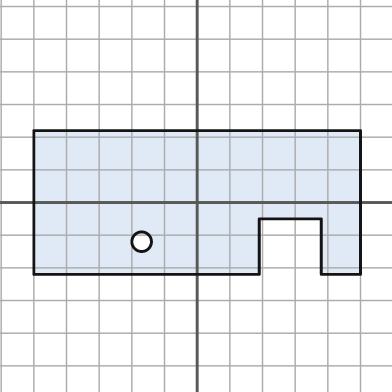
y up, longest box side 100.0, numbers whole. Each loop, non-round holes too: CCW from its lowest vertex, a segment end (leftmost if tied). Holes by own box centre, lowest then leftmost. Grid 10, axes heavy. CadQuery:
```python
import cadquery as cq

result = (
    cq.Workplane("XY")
    .moveTo(-50.0, -22.0)
    .lineTo(19.0, -22.0)
    .lineTo(19.0, -5.0)
    .lineTo(38.0, -5.0)
    .lineTo(38.0, -22.0)
    .lineTo(50.0, -22.0)
    .lineTo(50.0, 22.0)
    .lineTo(-50.0, 22.0)
    .close()
    .moveTo(-17.0, -12.0)
    .circle(3.0)
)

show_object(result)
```